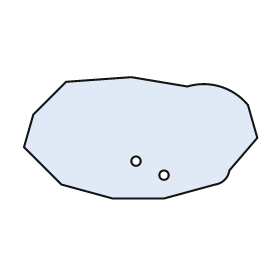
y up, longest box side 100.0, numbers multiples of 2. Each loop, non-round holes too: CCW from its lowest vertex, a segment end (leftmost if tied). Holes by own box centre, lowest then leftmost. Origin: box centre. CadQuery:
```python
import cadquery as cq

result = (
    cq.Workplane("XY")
    .moveTo(-12.0, -26.0)
    .lineTo(10.0, -26.0)
    .lineTo(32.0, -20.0)
    .threePointArc((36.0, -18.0), (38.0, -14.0))
    .lineTo(50.0, 0.0)
    .lineTo(46.0, 14.0)
    .threePointArc((34.0, 22.0), (20.0, 22.0))
    .lineTo(-4.0, 26.0)
    .lineTo(-32.0, 24.0)
    .lineTo(-46.0, 10.0)
    .lineTo(-50.0, -4.0)
    .lineTo(-34.0, -20.0)
    .close()
    .moveTo(10.0, -16.0)
    .circle(2.0)
    .moveTo(-2.0, -10.0)
    .circle(2.0)
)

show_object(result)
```